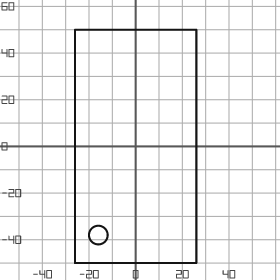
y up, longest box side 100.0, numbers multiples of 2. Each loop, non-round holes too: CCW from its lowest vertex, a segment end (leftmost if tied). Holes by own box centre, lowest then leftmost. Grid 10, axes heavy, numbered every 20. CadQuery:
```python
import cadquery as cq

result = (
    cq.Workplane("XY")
    .moveTo(-26.0, -50.0)
    .lineTo(26.0, -50.0)
    .lineTo(26.0, 50.0)
    .lineTo(-26.0, 50.0)
    .close()
    .moveTo(-16.0, -38.0)
    .circle(4.0)
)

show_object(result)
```